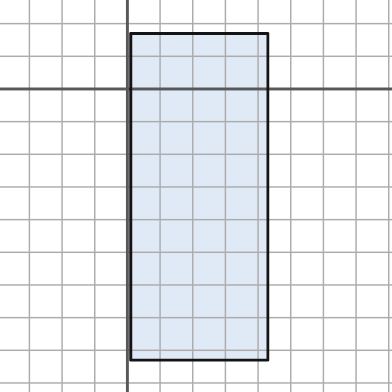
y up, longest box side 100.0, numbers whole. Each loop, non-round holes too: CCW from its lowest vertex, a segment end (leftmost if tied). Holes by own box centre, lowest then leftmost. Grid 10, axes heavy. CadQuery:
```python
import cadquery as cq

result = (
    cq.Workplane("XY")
    .moveTo(1.0, -83.0)
    .lineTo(43.0, -83.0)
    .lineTo(43.0, 17.0)
    .lineTo(1.0, 17.0)
    .close()
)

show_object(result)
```